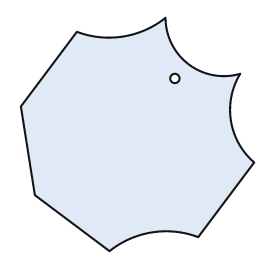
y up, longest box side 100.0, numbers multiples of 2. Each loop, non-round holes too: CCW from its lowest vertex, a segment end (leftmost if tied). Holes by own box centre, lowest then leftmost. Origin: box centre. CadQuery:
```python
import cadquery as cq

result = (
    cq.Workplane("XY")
    .moveTo(-12.0, -50.0)
    .threePointArc((6.0, -42.0), (26.0, -44.0))
    .lineTo(50.0, -12.0)
    .threePointArc((40.0, 6.0), (44.0, 26.0))
    .threePointArc((22.0, 30.0), (12.0, 50.0))
    .threePointArc((-6.0, 42.0), (-26.0, 44.0))
    .lineTo(-50.0, 12.0)
    .lineTo(-44.0, -26.0)
    .close()
    .moveTo(16.0, 24.0)
    .circle(2.0)
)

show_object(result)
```